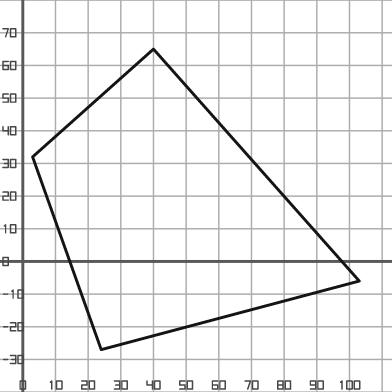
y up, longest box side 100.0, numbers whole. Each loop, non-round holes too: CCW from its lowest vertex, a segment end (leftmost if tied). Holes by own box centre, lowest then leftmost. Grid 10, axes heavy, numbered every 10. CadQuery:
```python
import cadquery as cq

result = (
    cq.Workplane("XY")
    .moveTo(24.0, -27.0)
    .lineTo(103.0, -6.0)
    .lineTo(40.0, 65.0)
    .lineTo(3.0, 32.0)
    .close()
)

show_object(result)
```